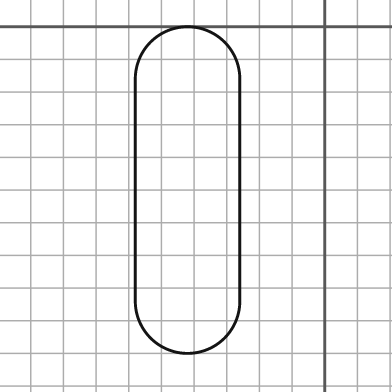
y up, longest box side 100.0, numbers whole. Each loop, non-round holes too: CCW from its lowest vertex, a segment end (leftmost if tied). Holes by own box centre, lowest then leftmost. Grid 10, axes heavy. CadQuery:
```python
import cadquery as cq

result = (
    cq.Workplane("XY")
    .moveTo(-58.0, -84.0)
    .threePointArc((-42.0, -100.0), (-26.0, -84.0))
    .lineTo(-26.0, -16.0)
    .threePointArc((-42.0, 0.0), (-58.0, -16.0))
    .close()
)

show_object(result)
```